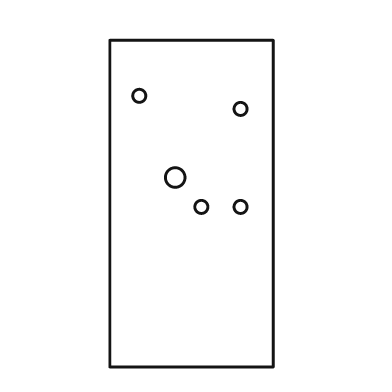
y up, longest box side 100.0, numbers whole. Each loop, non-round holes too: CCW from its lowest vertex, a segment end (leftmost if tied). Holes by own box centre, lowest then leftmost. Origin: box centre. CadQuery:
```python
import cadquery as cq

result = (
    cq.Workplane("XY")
    .moveTo(-25.0, -50.0)
    .lineTo(25.0, -50.0)
    .lineTo(25.0, 50.0)
    .lineTo(-25.0, 50.0)
    .close()
    .moveTo(3.0, -1.0)
    .circle(2.0)
    .moveTo(15.0, -1.0)
    .circle(2.0)
    .moveTo(-5.0, 8.0)
    .circle(3.0)
    .moveTo(15.0, 29.0)
    .circle(2.0)
    .moveTo(-16.0, 33.0)
    .circle(2.0)
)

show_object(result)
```